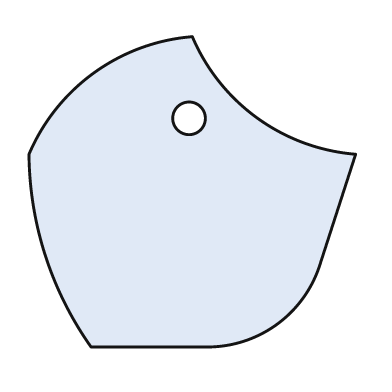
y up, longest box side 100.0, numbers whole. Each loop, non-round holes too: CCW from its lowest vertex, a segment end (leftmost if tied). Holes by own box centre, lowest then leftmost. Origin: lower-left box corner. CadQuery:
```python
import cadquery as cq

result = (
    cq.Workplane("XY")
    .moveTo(19.0, 0.0)
    .lineTo(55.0, 0.0)
    .threePointArc((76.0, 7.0), (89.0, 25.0))
    .lineTo(100.0, 59.0)
    .threePointArc((70.0, 70.0), (50.0, 95.0))
    .threePointArc((20.0, 84.0), (0.0, 59.0))
    .threePointArc((5.0, 28.0), (19.0, 0.0))
    .close()
    .moveTo(49.0, 70.0)
    .circle(5.0)
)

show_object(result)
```